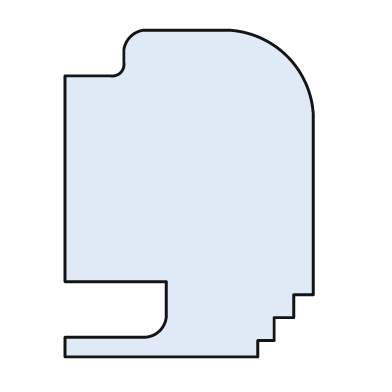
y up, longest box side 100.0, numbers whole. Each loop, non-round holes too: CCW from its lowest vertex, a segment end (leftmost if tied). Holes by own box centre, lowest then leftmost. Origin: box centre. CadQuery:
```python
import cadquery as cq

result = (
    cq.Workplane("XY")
    .moveTo(-38.0, -50.0)
    .lineTo(21.0, -50.0)
    .lineTo(21.0, -45.0)
    .lineTo(26.0, -45.0)
    .lineTo(26.0, -38.0)
    .lineTo(32.0, -38.0)
    .lineTo(32.0, -31.0)
    .lineTo(38.0, -31.0)
    .lineTo(38.0, 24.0)
    .threePointArc((30.0, 42.0), (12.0, 50.0))
    .lineTo(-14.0, 50.0)
    .threePointArc((-18.0, 48.0), (-20.0, 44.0))
    .lineTo(-20.0, 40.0)
    .threePointArc((-21.0, 37.0), (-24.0, 36.0))
    .lineTo(-38.0, 36.0)
    .lineTo(-38.0, -27.0)
    .lineTo(-7.0, -27.0)
    .lineTo(-7.0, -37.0)
    .threePointArc((-9.0, -42.0), (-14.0, -44.0))
    .lineTo(-38.0, -44.0)
    .close()
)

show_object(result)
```